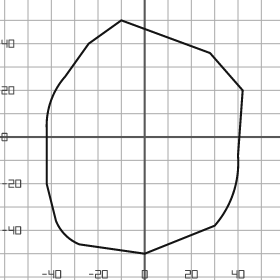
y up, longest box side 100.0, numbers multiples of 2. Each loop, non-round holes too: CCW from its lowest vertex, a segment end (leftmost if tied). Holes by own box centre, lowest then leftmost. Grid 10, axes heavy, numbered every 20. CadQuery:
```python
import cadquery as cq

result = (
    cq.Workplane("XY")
    .moveTo(0.0, -50.0)
    .lineTo(30.0, -38.0)
    .threePointArc((38.0, -24.0), (40.0, -8.0))
    .lineTo(42.0, 20.0)
    .lineTo(28.0, 36.0)
    .lineTo(-10.0, 50.0)
    .lineTo(-24.0, 40.0)
    .lineTo(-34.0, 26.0)
    .threePointArc((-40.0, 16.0), (-42.0, 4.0))
    .lineTo(-42.0, -20.0)
    .lineTo(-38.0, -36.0)
    .threePointArc((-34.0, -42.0), (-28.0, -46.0))
    .close()
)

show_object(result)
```